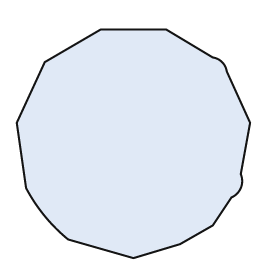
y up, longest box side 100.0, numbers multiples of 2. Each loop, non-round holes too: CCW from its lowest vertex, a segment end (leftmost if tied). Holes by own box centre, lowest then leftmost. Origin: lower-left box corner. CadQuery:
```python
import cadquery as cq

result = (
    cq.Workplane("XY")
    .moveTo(50.0, 0.0)
    .lineTo(70.0, 6.0)
    .lineTo(84.0, 14.0)
    .lineTo(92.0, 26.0)
    .threePointArc((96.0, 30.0), (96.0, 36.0))
    .lineTo(100.0, 58.0)
    .lineTo(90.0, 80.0)
    .threePointArc((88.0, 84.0), (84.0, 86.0))
    .lineTo(64.0, 98.0)
    .lineTo(36.0, 98.0)
    .lineTo(12.0, 84.0)
    .lineTo(0.0, 58.0)
    .lineTo(4.0, 30.0)
    .threePointArc((12.0, 18.0), (22.0, 8.0))
    .close()
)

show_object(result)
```